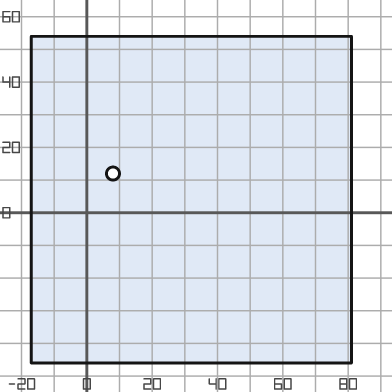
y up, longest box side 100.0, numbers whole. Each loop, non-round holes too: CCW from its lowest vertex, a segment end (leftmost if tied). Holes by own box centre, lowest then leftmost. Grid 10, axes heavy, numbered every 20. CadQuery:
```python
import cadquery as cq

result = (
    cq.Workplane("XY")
    .moveTo(-17.0, -46.0)
    .lineTo(81.0, -46.0)
    .lineTo(81.0, 54.0)
    .lineTo(-17.0, 54.0)
    .close()
    .moveTo(8.0, 12.0)
    .circle(2.0)
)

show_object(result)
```